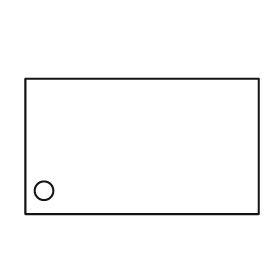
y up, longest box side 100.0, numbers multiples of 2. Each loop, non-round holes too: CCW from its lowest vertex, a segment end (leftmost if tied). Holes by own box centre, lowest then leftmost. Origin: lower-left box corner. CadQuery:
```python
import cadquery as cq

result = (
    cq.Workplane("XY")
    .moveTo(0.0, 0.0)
    .lineTo(100.0, 0.0)
    .lineTo(100.0, 58.0)
    .lineTo(0.0, 58.0)
    .close()
    .moveTo(8.0, 10.0)
    .circle(4.0)
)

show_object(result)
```